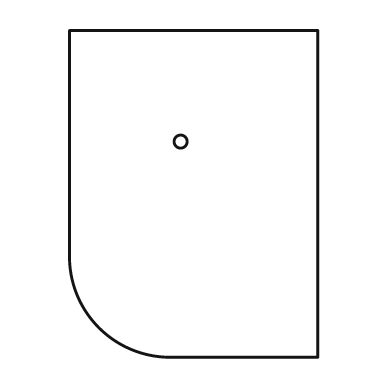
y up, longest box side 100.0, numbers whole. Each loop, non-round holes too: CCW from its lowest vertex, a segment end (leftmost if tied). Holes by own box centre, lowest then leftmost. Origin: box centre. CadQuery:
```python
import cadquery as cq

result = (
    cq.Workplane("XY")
    .moveTo(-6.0, -50.0)
    .lineTo(38.0, -50.0)
    .lineTo(38.0, 50.0)
    .lineTo(-38.0, 50.0)
    .lineTo(-38.0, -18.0)
    .threePointArc((-29.0, -41.0), (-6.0, -50.0))
    .close()
    .moveTo(-4.0, 16.0)
    .circle(2.0)
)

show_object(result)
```